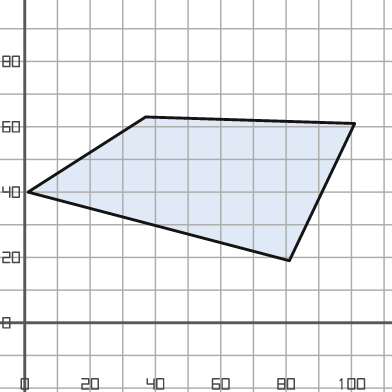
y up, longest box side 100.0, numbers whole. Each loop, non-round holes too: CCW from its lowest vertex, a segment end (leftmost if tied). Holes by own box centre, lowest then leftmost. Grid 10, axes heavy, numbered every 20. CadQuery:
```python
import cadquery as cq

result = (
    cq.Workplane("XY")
    .moveTo(81.0, 19.0)
    .lineTo(101.0, 61.0)
    .lineTo(37.0, 63.0)
    .lineTo(1.0, 40.0)
    .close()
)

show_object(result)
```